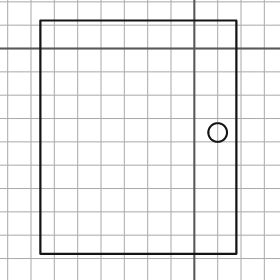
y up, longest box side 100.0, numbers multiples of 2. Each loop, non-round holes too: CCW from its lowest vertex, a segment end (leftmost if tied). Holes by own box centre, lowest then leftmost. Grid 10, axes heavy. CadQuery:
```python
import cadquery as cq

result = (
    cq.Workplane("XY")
    .moveTo(-66.0, -88.0)
    .lineTo(18.0, -88.0)
    .lineTo(18.0, 12.0)
    .lineTo(-66.0, 12.0)
    .close()
    .moveTo(10.0, -36.0)
    .circle(4.0)
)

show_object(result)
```